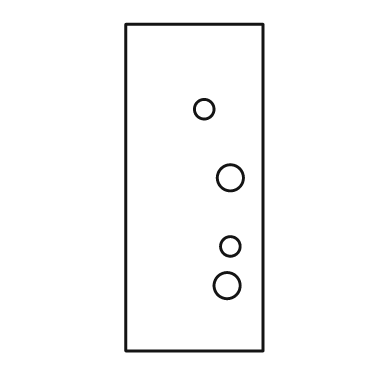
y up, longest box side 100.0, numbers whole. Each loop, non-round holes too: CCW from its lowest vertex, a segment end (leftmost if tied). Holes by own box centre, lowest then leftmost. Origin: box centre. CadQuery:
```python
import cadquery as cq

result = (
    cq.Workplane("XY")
    .moveTo(-21.0, -50.0)
    .lineTo(21.0, -50.0)
    .lineTo(21.0, 50.0)
    .lineTo(-21.0, 50.0)
    .close()
    .moveTo(10.0, -30.0)
    .circle(4.0)
    .moveTo(11.0, -18.0)
    .circle(3.0)
    .moveTo(11.0, 3.0)
    .circle(4.0)
    .moveTo(3.0, 24.0)
    .circle(3.0)
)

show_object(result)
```